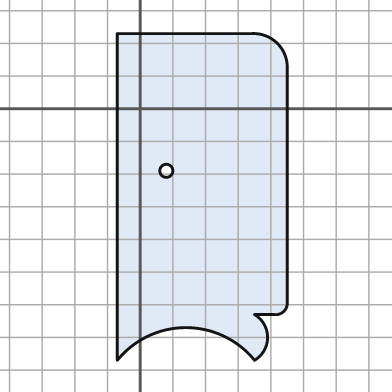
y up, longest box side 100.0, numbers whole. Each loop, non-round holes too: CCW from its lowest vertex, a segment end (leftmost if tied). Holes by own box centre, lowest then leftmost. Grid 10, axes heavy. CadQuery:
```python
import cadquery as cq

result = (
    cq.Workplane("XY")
    .moveTo(-7.0, -77.0)
    .threePointArc((14.0, -67.0), (35.0, -77.0))
    .threePointArc((39.0, -70.0), (35.0, -63.0))
    .lineTo(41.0, -63.0)
    .threePointArc((44.0, -62.0), (45.0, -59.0))
    .lineTo(45.0, 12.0)
    .threePointArc((42.0, 20.0), (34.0, 23.0))
    .lineTo(-7.0, 23.0)
    .close()
    .moveTo(8.0, -19.0)
    .circle(2.0)
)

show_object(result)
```